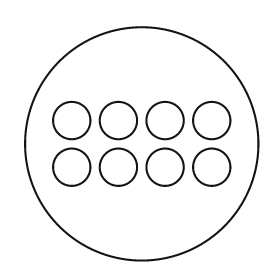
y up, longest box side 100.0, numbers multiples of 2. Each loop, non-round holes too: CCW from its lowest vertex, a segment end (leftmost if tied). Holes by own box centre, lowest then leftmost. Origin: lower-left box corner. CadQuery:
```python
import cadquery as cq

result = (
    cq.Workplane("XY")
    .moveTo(50.0, 50.0)
    .circle(50.0)
    .moveTo(20.0, 40.0)
    .circle(8.0)
    .moveTo(40.0, 40.0)
    .circle(8.0)
    .moveTo(60.0, 40.0)
    .circle(8.0)
    .moveTo(80.0, 40.0)
    .circle(8.0)
    .moveTo(20.0, 60.0)
    .circle(8.0)
    .moveTo(40.0, 60.0)
    .circle(8.0)
    .moveTo(60.0, 60.0)
    .circle(8.0)
    .moveTo(80.0, 60.0)
    .circle(8.0)
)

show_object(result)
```